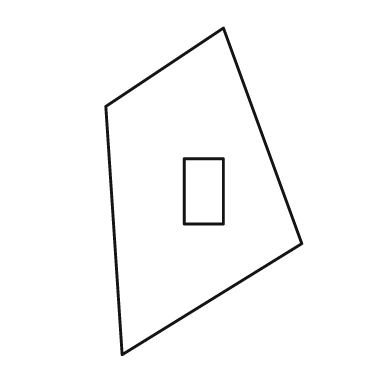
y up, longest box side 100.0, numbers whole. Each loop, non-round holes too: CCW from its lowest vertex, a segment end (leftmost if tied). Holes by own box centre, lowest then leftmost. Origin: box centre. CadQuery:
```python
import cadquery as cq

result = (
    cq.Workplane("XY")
    .moveTo(-25.0, -50.0)
    .lineTo(30.0, -16.0)
    .lineTo(6.0, 50.0)
    .lineTo(-30.0, 26.0)
    .close()
    .moveTo(-6.0, -10.0)
    .lineTo(6.0, -10.0)
    .lineTo(6.0, 10.0)
    .lineTo(-6.0, 10.0)
    .close()
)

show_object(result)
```